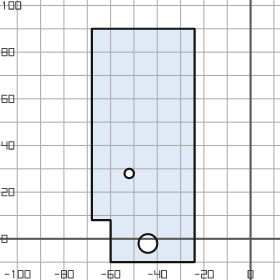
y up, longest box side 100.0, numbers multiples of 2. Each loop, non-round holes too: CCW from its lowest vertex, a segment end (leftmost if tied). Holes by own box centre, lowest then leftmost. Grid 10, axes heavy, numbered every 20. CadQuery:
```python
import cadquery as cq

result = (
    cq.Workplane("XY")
    .moveTo(-60.0, -10.0)
    .lineTo(-24.0, -10.0)
    .lineTo(-24.0, 90.0)
    .lineTo(-68.0, 90.0)
    .lineTo(-68.0, 8.0)
    .lineTo(-60.0, 8.0)
    .close()
    .moveTo(-44.0, -2.0)
    .circle(4.0)
    .moveTo(-52.0, 28.0)
    .circle(2.0)
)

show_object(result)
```